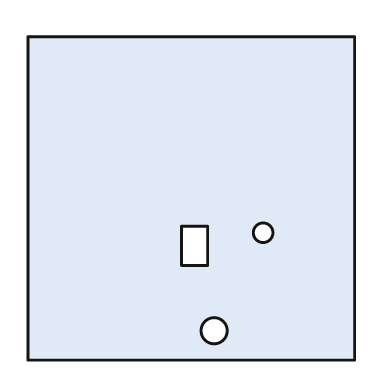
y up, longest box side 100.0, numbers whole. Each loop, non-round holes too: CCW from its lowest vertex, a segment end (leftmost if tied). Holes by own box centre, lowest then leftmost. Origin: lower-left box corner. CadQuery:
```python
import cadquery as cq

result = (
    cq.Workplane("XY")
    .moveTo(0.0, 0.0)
    .lineTo(100.0, 0.0)
    .lineTo(100.0, 99.0)
    .lineTo(0.0, 99.0)
    .close()
    .moveTo(57.0, 9.0)
    .circle(4.0)
    .moveTo(47.0, 29.0)
    .lineTo(55.0, 29.0)
    .lineTo(55.0, 41.0)
    .lineTo(47.0, 41.0)
    .close()
    .moveTo(72.0, 39.0)
    .circle(3.0)
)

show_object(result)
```